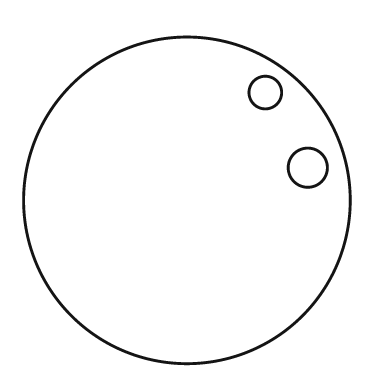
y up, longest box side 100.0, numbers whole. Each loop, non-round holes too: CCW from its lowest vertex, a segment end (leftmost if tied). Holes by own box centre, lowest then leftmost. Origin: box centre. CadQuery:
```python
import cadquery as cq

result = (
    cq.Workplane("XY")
    .moveTo(0.0, 0.0)
    .circle(50.0)
    .moveTo(37.0, 10.0)
    .circle(6.0)
    .moveTo(24.0, 33.0)
    .circle(5.0)
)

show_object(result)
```